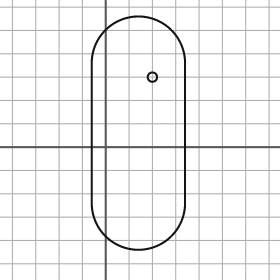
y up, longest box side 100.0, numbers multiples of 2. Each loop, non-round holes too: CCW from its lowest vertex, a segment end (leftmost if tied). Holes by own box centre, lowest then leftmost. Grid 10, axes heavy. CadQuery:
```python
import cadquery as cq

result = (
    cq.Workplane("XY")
    .moveTo(-6.0, -24.0)
    .threePointArc((14.0, -44.0), (34.0, -24.0))
    .lineTo(34.0, 36.0)
    .threePointArc((14.0, 56.0), (-6.0, 36.0))
    .close()
    .moveTo(20.0, 30.0)
    .circle(2.0)
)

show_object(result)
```